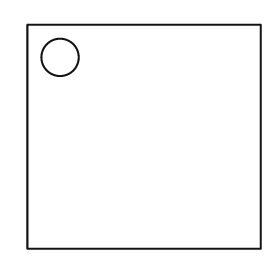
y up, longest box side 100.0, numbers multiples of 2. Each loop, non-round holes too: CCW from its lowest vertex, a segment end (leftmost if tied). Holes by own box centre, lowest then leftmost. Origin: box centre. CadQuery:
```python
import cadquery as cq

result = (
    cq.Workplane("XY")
    .moveTo(-50.0, -48.0)
    .lineTo(50.0, -48.0)
    .lineTo(50.0, 48.0)
    .lineTo(-50.0, 48.0)
    .close()
    .moveTo(-36.0, 34.0)
    .circle(8.0)
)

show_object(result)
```